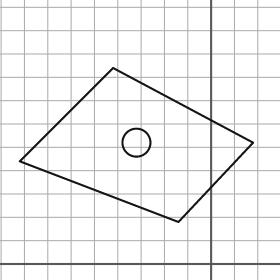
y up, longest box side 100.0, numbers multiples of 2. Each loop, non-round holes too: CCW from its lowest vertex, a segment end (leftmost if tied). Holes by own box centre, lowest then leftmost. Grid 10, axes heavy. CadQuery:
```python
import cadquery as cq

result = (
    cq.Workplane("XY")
    .moveTo(-14.0, 18.0)
    .lineTo(18.0, 52.0)
    .lineTo(-42.0, 84.0)
    .lineTo(-82.0, 44.0)
    .close()
    .moveTo(-32.0, 52.0)
    .circle(6.0)
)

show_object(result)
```